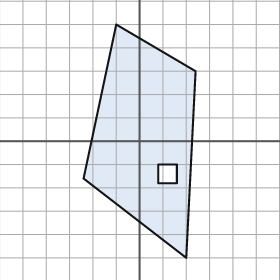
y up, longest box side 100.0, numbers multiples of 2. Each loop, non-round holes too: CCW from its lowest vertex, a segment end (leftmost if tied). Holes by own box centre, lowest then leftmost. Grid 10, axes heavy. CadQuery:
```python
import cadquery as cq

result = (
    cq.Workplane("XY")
    .moveTo(20.0, -50.0)
    .lineTo(24.0, 30.0)
    .lineTo(-10.0, 50.0)
    .lineTo(-24.0, -16.0)
    .close()
    .moveTo(8.0, -18.0)
    .lineTo(16.0, -18.0)
    .lineTo(16.0, -10.0)
    .lineTo(8.0, -10.0)
    .close()
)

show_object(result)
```